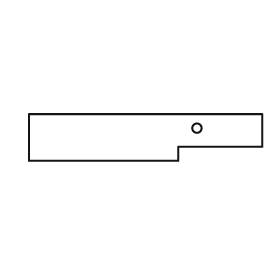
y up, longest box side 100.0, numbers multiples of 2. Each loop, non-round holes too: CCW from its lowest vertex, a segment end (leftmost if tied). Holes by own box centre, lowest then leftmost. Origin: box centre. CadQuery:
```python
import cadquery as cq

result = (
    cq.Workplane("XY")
    .moveTo(-50.0, -10.0)
    .lineTo(14.0, -10.0)
    .lineTo(14.0, -4.0)
    .lineTo(50.0, -4.0)
    .lineTo(50.0, 10.0)
    .lineTo(-50.0, 10.0)
    .close()
    .moveTo(22.0, 4.0)
    .circle(2.0)
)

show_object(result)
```